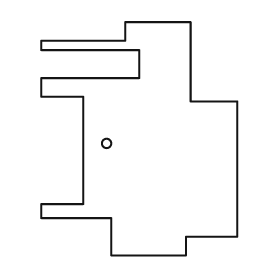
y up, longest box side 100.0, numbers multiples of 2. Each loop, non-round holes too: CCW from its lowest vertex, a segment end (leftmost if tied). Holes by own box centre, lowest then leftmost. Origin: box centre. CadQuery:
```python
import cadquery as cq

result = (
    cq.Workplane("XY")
    .moveTo(-12.0, -50.0)
    .lineTo(20.0, -50.0)
    .lineTo(20.0, -42.0)
    .lineTo(42.0, -42.0)
    .lineTo(42.0, 16.0)
    .lineTo(22.0, 16.0)
    .lineTo(22.0, 50.0)
    .lineTo(-6.0, 50.0)
    .lineTo(-6.0, 42.0)
    .lineTo(-42.0, 42.0)
    .lineTo(-42.0, 38.0)
    .lineTo(0.0, 38.0)
    .lineTo(0.0, 26.0)
    .lineTo(-42.0, 26.0)
    .lineTo(-42.0, 18.0)
    .lineTo(-24.0, 18.0)
    .lineTo(-24.0, -28.0)
    .lineTo(-42.0, -28.0)
    .lineTo(-42.0, -34.0)
    .lineTo(-12.0, -34.0)
    .close()
    .moveTo(-14.0, -2.0)
    .circle(2.0)
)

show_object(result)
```